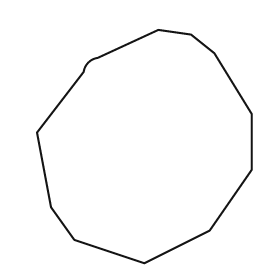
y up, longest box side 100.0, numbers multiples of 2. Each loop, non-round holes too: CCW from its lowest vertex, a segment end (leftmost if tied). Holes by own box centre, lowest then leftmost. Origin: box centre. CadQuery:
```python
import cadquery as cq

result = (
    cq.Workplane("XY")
    .moveTo(0.0, -50.0)
    .lineTo(28.0, -36.0)
    .lineTo(46.0, -10.0)
    .lineTo(46.0, 14.0)
    .lineTo(30.0, 40.0)
    .lineTo(20.0, 48.0)
    .lineTo(6.0, 50.0)
    .lineTo(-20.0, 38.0)
    .threePointArc((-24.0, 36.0), (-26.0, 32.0))
    .lineTo(-46.0, 6.0)
    .lineTo(-40.0, -26.0)
    .lineTo(-30.0, -40.0)
    .close()
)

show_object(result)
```